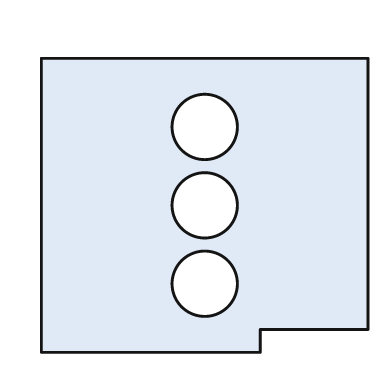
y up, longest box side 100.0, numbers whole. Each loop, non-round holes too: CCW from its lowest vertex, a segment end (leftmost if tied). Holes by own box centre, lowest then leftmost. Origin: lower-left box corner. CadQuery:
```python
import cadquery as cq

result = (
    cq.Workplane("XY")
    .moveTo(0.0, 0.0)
    .lineTo(67.0, 0.0)
    .lineTo(67.0, 7.0)
    .lineTo(100.0, 7.0)
    .lineTo(100.0, 90.0)
    .lineTo(0.0, 90.0)
    .close()
    .moveTo(50.0, 21.0)
    .circle(10.0)
    .moveTo(50.0, 45.0)
    .circle(10.0)
    .moveTo(50.0, 69.0)
    .circle(10.0)
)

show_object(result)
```